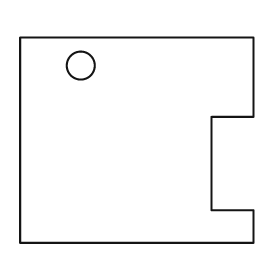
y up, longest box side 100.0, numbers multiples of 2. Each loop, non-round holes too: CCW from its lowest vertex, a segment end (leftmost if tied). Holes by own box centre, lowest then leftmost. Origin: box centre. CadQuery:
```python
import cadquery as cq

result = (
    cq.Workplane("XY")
    .moveTo(-50.0, -44.0)
    .lineTo(50.0, -44.0)
    .lineTo(50.0, -30.0)
    .lineTo(32.0, -30.0)
    .lineTo(32.0, 10.0)
    .lineTo(50.0, 10.0)
    .lineTo(50.0, 44.0)
    .lineTo(-50.0, 44.0)
    .close()
    .moveTo(-24.0, 32.0)
    .circle(6.0)
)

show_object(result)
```